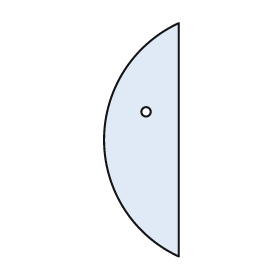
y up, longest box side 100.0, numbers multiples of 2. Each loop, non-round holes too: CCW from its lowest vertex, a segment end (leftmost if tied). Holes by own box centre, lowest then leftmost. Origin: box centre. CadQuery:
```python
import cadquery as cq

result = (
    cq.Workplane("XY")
    .moveTo(16.0, -50.0)
    .lineTo(16.0, 50.0)
    .threePointArc((-16.0, 0.0), (16.0, -50.0))
    .close()
    .moveTo(2.0, 12.0)
    .circle(2.0)
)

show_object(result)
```